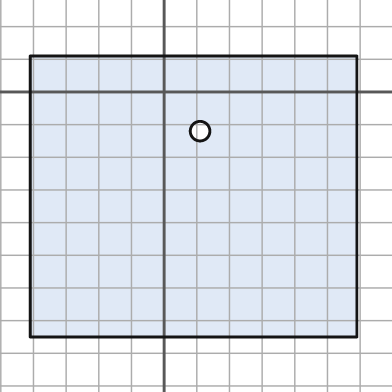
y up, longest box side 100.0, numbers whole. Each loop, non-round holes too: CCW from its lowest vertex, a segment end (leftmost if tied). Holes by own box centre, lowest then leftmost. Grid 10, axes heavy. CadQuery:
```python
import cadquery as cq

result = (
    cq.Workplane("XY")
    .moveTo(-41.0, -75.0)
    .lineTo(59.0, -75.0)
    .lineTo(59.0, 11.0)
    .lineTo(-41.0, 11.0)
    .close()
    .moveTo(11.0, -12.0)
    .circle(3.0)
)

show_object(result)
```